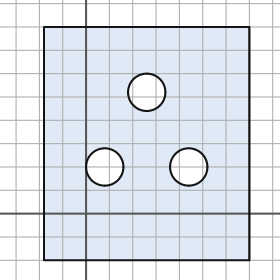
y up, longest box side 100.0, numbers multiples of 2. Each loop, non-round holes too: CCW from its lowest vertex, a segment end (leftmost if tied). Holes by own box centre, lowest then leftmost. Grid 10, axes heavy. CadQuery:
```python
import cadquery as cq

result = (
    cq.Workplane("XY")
    .moveTo(-18.0, -20.0)
    .lineTo(70.0, -20.0)
    .lineTo(70.0, 80.0)
    .lineTo(-18.0, 80.0)
    .close()
    .moveTo(8.0, 20.0)
    .circle(8.0)
    .moveTo(44.0, 20.0)
    .circle(8.0)
    .moveTo(26.0, 52.0)
    .circle(8.0)
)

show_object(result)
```